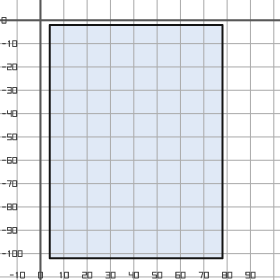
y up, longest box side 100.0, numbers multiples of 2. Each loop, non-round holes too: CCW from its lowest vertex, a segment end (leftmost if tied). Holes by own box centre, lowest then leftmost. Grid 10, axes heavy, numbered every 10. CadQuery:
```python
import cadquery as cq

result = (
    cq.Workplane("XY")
    .moveTo(4.0, -102.0)
    .lineTo(78.0, -102.0)
    .lineTo(78.0, -2.0)
    .lineTo(4.0, -2.0)
    .close()
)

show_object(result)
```